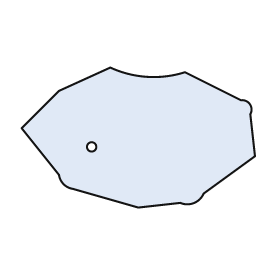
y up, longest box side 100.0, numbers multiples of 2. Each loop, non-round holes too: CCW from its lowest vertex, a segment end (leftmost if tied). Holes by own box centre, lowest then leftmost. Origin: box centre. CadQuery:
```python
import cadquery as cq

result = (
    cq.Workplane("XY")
    .moveTo(0.0, -30.0)
    .lineTo(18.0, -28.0)
    .threePointArc((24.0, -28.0), (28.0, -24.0))
    .lineTo(50.0, -8.0)
    .lineTo(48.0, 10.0)
    .threePointArc((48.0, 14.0), (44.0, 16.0))
    .lineTo(20.0, 28.0)
    .threePointArc((4.0, 26.0), (-12.0, 30.0))
    .lineTo(-34.0, 20.0)
    .lineTo(-50.0, 4.0)
    .lineTo(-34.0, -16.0)
    .threePointArc((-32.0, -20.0), (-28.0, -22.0))
    .close()
    .moveTo(-20.0, -4.0)
    .circle(2.0)
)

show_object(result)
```